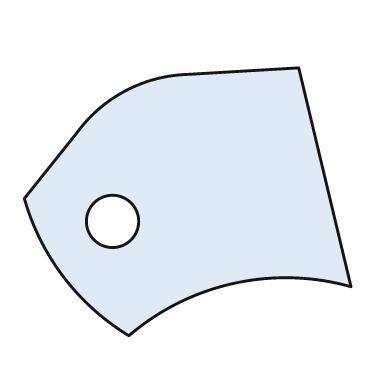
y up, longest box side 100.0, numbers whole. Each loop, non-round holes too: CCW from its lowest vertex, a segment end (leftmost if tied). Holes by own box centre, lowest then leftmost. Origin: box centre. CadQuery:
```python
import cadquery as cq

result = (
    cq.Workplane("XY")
    .moveTo(-18.0, -41.0)
    .threePointArc((14.0, -25.0), (50.0, -26.0))
    .lineTo(34.0, 41.0)
    .lineTo(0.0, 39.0)
    .threePointArc((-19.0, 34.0), (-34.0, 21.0))
    .lineTo(-50.0, 1.0)
    .threePointArc((-38.0, -23.0), (-18.0, -41.0))
    .close()
    .moveTo(-23.0, -6.0)
    .circle(8.0)
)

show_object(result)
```